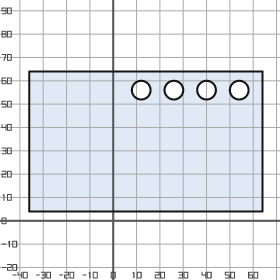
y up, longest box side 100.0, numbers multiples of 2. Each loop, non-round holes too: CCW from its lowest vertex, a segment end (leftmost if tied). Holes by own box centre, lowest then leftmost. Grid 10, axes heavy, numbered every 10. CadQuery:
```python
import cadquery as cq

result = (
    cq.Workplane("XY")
    .moveTo(-36.0, 4.0)
    .lineTo(64.0, 4.0)
    .lineTo(64.0, 64.0)
    .lineTo(-36.0, 64.0)
    .close()
    .moveTo(12.0, 56.0)
    .circle(4.0)
    .moveTo(26.0, 56.0)
    .circle(4.0)
    .moveTo(40.0, 56.0)
    .circle(4.0)
    .moveTo(54.0, 56.0)
    .circle(4.0)
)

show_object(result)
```